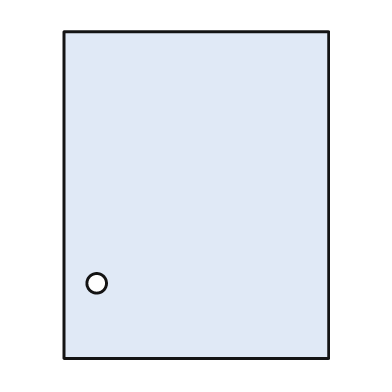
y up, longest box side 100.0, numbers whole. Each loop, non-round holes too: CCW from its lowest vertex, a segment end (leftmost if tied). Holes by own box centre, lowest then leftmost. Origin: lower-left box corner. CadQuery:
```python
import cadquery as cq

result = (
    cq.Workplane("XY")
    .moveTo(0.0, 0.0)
    .lineTo(81.0, 0.0)
    .lineTo(81.0, 100.0)
    .lineTo(0.0, 100.0)
    .close()
    .moveTo(10.0, 23.0)
    .circle(3.0)
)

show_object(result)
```